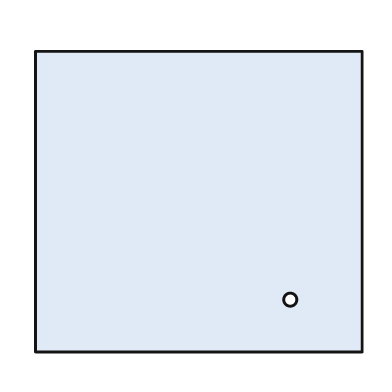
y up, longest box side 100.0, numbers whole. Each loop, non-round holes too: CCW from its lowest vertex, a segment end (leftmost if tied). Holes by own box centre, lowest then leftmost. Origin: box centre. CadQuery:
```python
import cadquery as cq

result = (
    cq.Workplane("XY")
    .moveTo(-50.0, -46.0)
    .lineTo(50.0, -46.0)
    .lineTo(50.0, 46.0)
    .lineTo(-50.0, 46.0)
    .close()
    .moveTo(28.0, -30.0)
    .circle(2.0)
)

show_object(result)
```